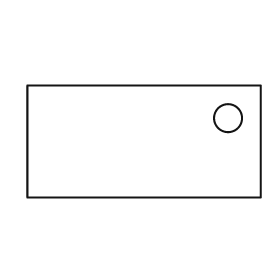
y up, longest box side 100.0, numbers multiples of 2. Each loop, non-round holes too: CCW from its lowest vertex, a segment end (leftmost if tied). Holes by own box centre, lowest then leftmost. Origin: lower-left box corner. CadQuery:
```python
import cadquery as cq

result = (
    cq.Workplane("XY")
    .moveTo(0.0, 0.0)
    .lineTo(100.0, 0.0)
    .lineTo(100.0, 48.0)
    .lineTo(0.0, 48.0)
    .close()
    .moveTo(86.0, 34.0)
    .circle(6.0)
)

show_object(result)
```